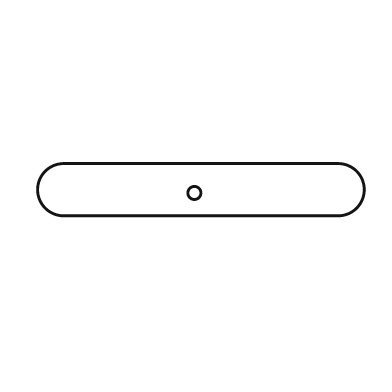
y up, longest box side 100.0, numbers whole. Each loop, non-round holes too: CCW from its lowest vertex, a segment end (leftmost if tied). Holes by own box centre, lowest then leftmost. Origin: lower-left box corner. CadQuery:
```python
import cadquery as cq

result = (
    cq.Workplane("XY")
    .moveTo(8.0, 0.0)
    .lineTo(92.0, 0.0)
    .threePointArc((100.0, 8.0), (92.0, 16.0))
    .lineTo(8.0, 16.0)
    .threePointArc((0.0, 8.0), (8.0, 0.0))
    .close()
    .moveTo(48.0, 7.0)
    .circle(2.0)
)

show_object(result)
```